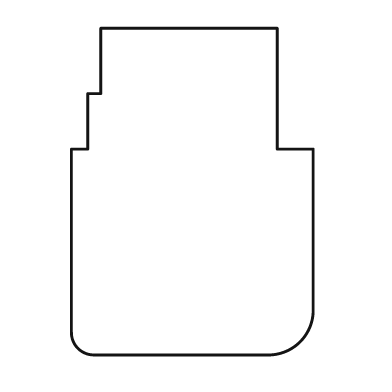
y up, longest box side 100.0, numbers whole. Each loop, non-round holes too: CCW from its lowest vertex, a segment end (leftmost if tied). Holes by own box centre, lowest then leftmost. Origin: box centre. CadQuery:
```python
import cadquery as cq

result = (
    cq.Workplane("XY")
    .moveTo(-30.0, -50.0)
    .lineTo(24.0, -50.0)
    .threePointArc((33.0, -46.0), (37.0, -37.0))
    .lineTo(37.0, 13.0)
    .lineTo(26.0, 13.0)
    .lineTo(26.0, 50.0)
    .lineTo(-28.0, 50.0)
    .lineTo(-28.0, 30.0)
    .lineTo(-32.0, 30.0)
    .lineTo(-32.0, 13.0)
    .lineTo(-37.0, 13.0)
    .lineTo(-37.0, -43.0)
    .threePointArc((-35.0, -48.0), (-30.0, -50.0))
    .close()
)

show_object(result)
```